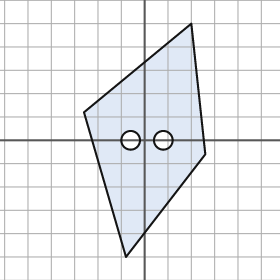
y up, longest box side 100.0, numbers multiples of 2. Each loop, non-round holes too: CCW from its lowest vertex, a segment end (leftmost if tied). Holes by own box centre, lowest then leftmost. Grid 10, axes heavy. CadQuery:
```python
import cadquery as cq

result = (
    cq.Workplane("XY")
    .moveTo(-8.0, -50.0)
    .lineTo(26.0, -6.0)
    .lineTo(20.0, 50.0)
    .lineTo(-26.0, 12.0)
    .close()
    .moveTo(-6.0, 0.0)
    .circle(4.0)
    .moveTo(8.0, 0.0)
    .circle(4.0)
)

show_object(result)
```